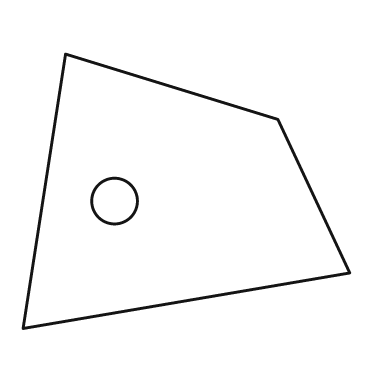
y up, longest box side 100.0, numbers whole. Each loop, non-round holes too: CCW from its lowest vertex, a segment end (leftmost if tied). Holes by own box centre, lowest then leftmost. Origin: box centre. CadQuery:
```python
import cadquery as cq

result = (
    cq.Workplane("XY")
    .moveTo(-50.0, -42.0)
    .lineTo(50.0, -25.0)
    .lineTo(28.0, 22.0)
    .lineTo(-37.0, 42.0)
    .close()
    .moveTo(-22.0, -3.0)
    .circle(7.0)
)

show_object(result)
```